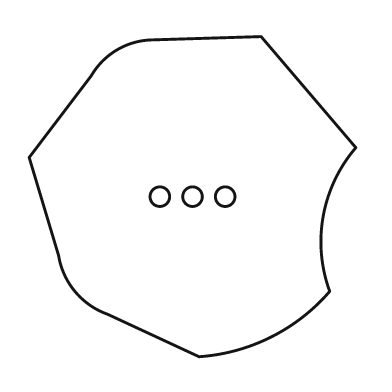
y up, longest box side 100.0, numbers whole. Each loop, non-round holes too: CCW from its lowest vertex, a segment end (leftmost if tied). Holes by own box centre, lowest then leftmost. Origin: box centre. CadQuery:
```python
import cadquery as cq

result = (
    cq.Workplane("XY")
    .moveTo(2.0, -49.0)
    .threePointArc((24.0, -43.0), (42.0, -29.0))
    .threePointArc((40.0, -6.0), (50.0, 15.0))
    .lineTo(21.0, 49.0)
    .lineTo(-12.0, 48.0)
    .threePointArc((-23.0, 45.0), (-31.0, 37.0))
    .lineTo(-50.0, 12.0)
    .lineTo(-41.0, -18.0)
    .threePointArc((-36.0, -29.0), (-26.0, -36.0))
    .close()
    .moveTo(-10.0, 0.0)
    .circle(3.0)
    .moveTo(0.0, 0.0)
    .circle(3.0)
    .moveTo(10.0, 0.0)
    .circle(3.0)
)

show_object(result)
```